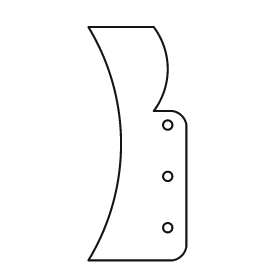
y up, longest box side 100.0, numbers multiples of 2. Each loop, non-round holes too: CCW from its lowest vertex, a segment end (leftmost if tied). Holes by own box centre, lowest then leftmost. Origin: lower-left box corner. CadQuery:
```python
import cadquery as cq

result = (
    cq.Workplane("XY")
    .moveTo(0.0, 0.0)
    .lineTo(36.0, 0.0)
    .threePointArc((40.0, 2.0), (42.0, 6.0))
    .lineTo(42.0, 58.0)
    .threePointArc((40.0, 62.0), (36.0, 64.0))
    .lineTo(28.0, 64.0)
    .threePointArc((34.0, 82.0), (28.0, 100.0))
    .lineTo(0.0, 100.0)
    .threePointArc((14.0, 50.0), (0.0, 0.0))
    .close()
    .moveTo(34.0, 14.0)
    .circle(2.0)
    .moveTo(34.0, 36.0)
    .circle(2.0)
    .moveTo(34.0, 58.0)
    .circle(2.0)
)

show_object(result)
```